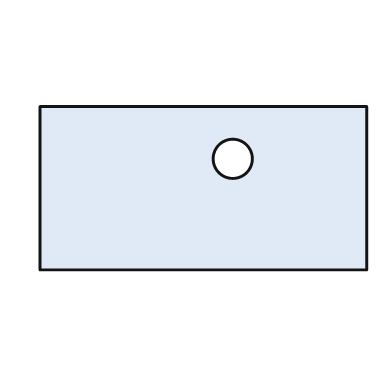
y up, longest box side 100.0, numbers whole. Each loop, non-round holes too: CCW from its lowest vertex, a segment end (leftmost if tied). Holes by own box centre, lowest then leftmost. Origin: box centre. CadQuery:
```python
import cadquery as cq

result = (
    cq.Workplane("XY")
    .moveTo(-50.0, -25.0)
    .lineTo(50.0, -25.0)
    .lineTo(50.0, 25.0)
    .lineTo(-50.0, 25.0)
    .close()
    .moveTo(9.0, 9.0)
    .circle(6.0)
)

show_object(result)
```